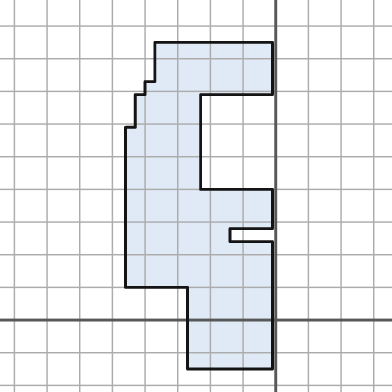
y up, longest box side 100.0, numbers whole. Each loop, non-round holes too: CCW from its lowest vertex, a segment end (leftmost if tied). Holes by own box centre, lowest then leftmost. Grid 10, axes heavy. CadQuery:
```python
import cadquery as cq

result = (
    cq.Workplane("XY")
    .moveTo(-27.0, -15.0)
    .lineTo(-1.0, -15.0)
    .lineTo(-1.0, 24.0)
    .lineTo(-14.0, 24.0)
    .lineTo(-14.0, 28.0)
    .lineTo(-1.0, 28.0)
    .lineTo(-1.0, 40.0)
    .lineTo(-23.0, 40.0)
    .lineTo(-23.0, 69.0)
    .lineTo(-1.0, 69.0)
    .lineTo(-1.0, 85.0)
    .lineTo(-37.0, 85.0)
    .lineTo(-37.0, 73.0)
    .lineTo(-40.0, 73.0)
    .lineTo(-40.0, 69.0)
    .lineTo(-43.0, 69.0)
    .lineTo(-43.0, 59.0)
    .lineTo(-46.0, 59.0)
    .lineTo(-46.0, 10.0)
    .lineTo(-27.0, 10.0)
    .close()
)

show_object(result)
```